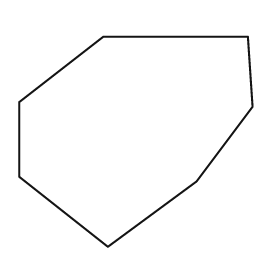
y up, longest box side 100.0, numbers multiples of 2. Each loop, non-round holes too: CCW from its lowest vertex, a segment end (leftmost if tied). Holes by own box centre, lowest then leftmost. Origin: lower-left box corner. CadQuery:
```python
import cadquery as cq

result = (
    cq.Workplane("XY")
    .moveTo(38.0, 0.0)
    .lineTo(76.0, 28.0)
    .lineTo(100.0, 60.0)
    .lineTo(98.0, 90.0)
    .lineTo(36.0, 90.0)
    .lineTo(0.0, 62.0)
    .lineTo(0.0, 30.0)
    .close()
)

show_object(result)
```